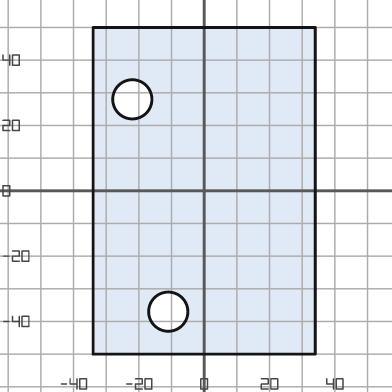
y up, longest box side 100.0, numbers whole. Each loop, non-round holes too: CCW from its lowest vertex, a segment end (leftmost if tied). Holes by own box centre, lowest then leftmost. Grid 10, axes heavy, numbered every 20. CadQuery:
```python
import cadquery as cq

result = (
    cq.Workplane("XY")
    .moveTo(-34.0, -50.0)
    .lineTo(34.0, -50.0)
    .lineTo(34.0, 50.0)
    .lineTo(-34.0, 50.0)
    .close()
    .moveTo(-11.0, -37.0)
    .circle(6.0)
    .moveTo(-22.0, 28.0)
    .circle(6.0)
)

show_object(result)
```